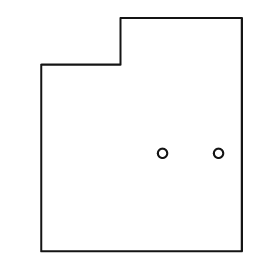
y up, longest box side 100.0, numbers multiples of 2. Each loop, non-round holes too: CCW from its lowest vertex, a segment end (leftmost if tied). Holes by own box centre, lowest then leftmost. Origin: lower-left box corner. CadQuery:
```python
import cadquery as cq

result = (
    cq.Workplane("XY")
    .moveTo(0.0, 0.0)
    .lineTo(86.0, 0.0)
    .lineTo(86.0, 100.0)
    .lineTo(34.0, 100.0)
    .lineTo(34.0, 80.0)
    .lineTo(0.0, 80.0)
    .close()
    .moveTo(52.0, 42.0)
    .circle(2.0)
    .moveTo(76.0, 42.0)
    .circle(2.0)
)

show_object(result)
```